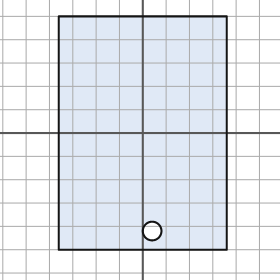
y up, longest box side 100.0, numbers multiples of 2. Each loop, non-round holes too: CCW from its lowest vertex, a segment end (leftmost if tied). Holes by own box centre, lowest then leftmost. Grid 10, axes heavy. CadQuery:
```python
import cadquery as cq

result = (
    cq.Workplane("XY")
    .moveTo(-36.0, -50.0)
    .lineTo(36.0, -50.0)
    .lineTo(36.0, 50.0)
    .lineTo(-36.0, 50.0)
    .close()
    .moveTo(4.0, -42.0)
    .circle(4.0)
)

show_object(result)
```